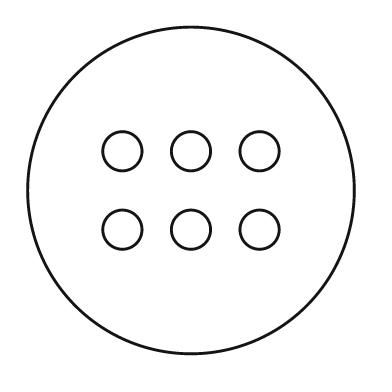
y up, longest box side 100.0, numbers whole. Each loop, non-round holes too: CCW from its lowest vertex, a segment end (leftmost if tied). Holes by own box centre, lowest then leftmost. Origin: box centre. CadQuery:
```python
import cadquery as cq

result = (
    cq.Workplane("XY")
    .moveTo(0.0, 0.0)
    .circle(50.0)
    .moveTo(-21.0, -12.0)
    .circle(6.0)
    .moveTo(0.0, -12.0)
    .circle(6.0)
    .moveTo(21.0, -12.0)
    .circle(6.0)
    .moveTo(-21.0, 12.0)
    .circle(6.0)
    .moveTo(0.0, 12.0)
    .circle(6.0)
    .moveTo(21.0, 12.0)
    .circle(6.0)
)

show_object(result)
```